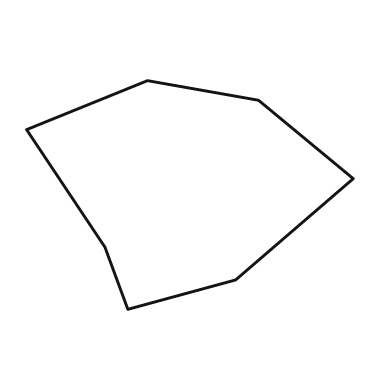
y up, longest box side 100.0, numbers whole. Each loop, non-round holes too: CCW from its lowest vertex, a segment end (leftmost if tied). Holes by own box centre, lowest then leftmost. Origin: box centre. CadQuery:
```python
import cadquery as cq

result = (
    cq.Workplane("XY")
    .moveTo(-19.0, -35.0)
    .lineTo(14.0, -26.0)
    .lineTo(50.0, 5.0)
    .lineTo(21.0, 29.0)
    .lineTo(-13.0, 35.0)
    .lineTo(-50.0, 20.0)
    .lineTo(-26.0, -16.0)
    .close()
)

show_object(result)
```